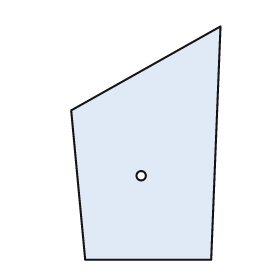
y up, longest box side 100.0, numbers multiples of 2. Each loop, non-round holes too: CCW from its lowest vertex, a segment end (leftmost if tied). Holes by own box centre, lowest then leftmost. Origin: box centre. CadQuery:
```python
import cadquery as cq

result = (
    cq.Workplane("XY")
    .moveTo(-26.0, -50.0)
    .lineTo(28.0, -50.0)
    .lineTo(32.0, 50.0)
    .lineTo(-32.0, 14.0)
    .close()
    .moveTo(-2.0, -14.0)
    .circle(2.0)
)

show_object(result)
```